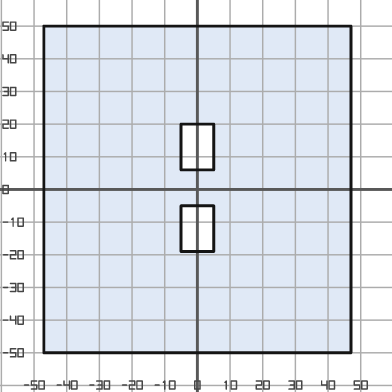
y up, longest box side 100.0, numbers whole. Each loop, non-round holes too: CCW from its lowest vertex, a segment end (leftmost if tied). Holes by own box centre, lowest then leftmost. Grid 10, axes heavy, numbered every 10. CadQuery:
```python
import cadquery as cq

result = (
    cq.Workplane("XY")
    .moveTo(-47.0, -50.0)
    .lineTo(47.0, -50.0)
    .lineTo(47.0, 50.0)
    .lineTo(-47.0, 50.0)
    .close()
    .moveTo(-5.0, -19.0)
    .lineTo(5.0, -19.0)
    .lineTo(5.0, -5.0)
    .lineTo(-5.0, -5.0)
    .close()
    .moveTo(-5.0, 6.0)
    .lineTo(5.0, 6.0)
    .lineTo(5.0, 20.0)
    .lineTo(-5.0, 20.0)
    .close()
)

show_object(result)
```